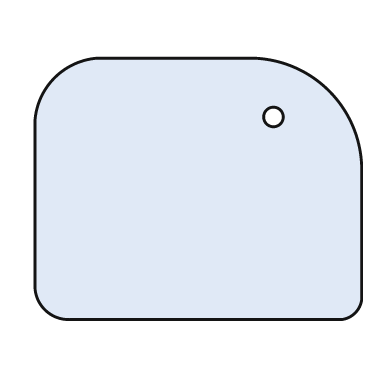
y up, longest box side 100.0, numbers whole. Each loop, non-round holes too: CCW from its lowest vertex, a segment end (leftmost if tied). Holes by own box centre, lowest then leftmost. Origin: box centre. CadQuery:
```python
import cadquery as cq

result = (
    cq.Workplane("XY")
    .moveTo(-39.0, -40.0)
    .lineTo(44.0, -40.0)
    .threePointArc((48.0, -38.0), (50.0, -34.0))
    .lineTo(50.0, 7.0)
    .threePointArc((40.0, 30.0), (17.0, 40.0))
    .lineTo(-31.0, 40.0)
    .threePointArc((-44.0, 34.0), (-50.0, 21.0))
    .lineTo(-50.0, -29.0)
    .threePointArc((-47.0, -37.0), (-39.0, -40.0))
    .close()
    .moveTo(23.0, 22.0)
    .circle(3.0)
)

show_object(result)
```